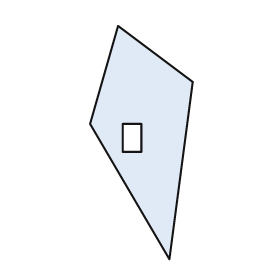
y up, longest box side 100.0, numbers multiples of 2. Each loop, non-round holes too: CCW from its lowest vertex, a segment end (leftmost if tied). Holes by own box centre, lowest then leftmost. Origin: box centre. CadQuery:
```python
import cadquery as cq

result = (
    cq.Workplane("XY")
    .moveTo(12.0, -50.0)
    .lineTo(22.0, 26.0)
    .lineTo(-10.0, 50.0)
    .lineTo(-22.0, 8.0)
    .close()
    .moveTo(-8.0, -4.0)
    .lineTo(0.0, -4.0)
    .lineTo(0.0, 8.0)
    .lineTo(-8.0, 8.0)
    .close()
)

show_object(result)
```